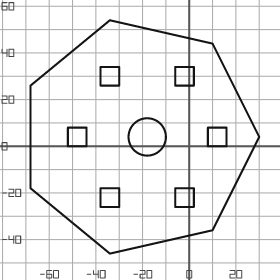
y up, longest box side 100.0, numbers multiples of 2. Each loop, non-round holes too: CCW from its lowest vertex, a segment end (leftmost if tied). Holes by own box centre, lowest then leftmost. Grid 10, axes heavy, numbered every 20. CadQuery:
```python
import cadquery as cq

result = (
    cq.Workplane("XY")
    .moveTo(-34.0, -46.0)
    .lineTo(10.0, -36.0)
    .lineTo(30.0, 4.0)
    .lineTo(10.0, 44.0)
    .lineTo(-34.0, 54.0)
    .lineTo(-68.0, 26.0)
    .lineTo(-68.0, -18.0)
    .close()
    .moveTo(-38.0, -26.0)
    .lineTo(-30.0, -26.0)
    .lineTo(-30.0, -18.0)
    .lineTo(-38.0, -18.0)
    .close()
    .moveTo(-6.0, -26.0)
    .lineTo(2.0, -26.0)
    .lineTo(2.0, -18.0)
    .lineTo(-6.0, -18.0)
    .close()
    .moveTo(-52.0, 0.0)
    .lineTo(-44.0, 0.0)
    .lineTo(-44.0, 8.0)
    .lineTo(-52.0, 8.0)
    .close()
    .moveTo(-18.0, 4.0)
    .circle(8.0)
    .moveTo(8.0, 0.0)
    .lineTo(16.0, 0.0)
    .lineTo(16.0, 8.0)
    .lineTo(8.0, 8.0)
    .close()
    .moveTo(-38.0, 26.0)
    .lineTo(-30.0, 26.0)
    .lineTo(-30.0, 34.0)
    .lineTo(-38.0, 34.0)
    .close()
    .moveTo(-6.0, 26.0)
    .lineTo(2.0, 26.0)
    .lineTo(2.0, 34.0)
    .lineTo(-6.0, 34.0)
    .close()
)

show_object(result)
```